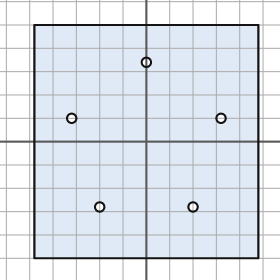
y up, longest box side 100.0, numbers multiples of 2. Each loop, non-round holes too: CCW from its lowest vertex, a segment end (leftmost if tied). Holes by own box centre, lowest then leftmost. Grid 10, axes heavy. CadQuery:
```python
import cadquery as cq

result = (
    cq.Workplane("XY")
    .moveTo(-48.0, -50.0)
    .lineTo(48.0, -50.0)
    .lineTo(48.0, 50.0)
    .lineTo(-48.0, 50.0)
    .close()
    .moveTo(-20.0, -28.0)
    .circle(2.0)
    .moveTo(20.0, -28.0)
    .circle(2.0)
    .moveTo(-32.0, 10.0)
    .circle(2.0)
    .moveTo(32.0, 10.0)
    .circle(2.0)
    .moveTo(0.0, 34.0)
    .circle(2.0)
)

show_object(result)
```